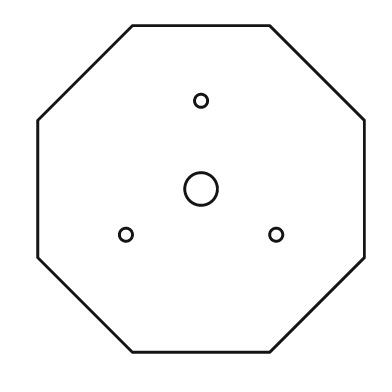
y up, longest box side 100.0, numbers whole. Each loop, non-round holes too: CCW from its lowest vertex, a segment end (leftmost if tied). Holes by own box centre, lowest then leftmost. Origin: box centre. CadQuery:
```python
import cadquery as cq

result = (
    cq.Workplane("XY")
    .moveTo(-21.0, -50.0)
    .lineTo(21.0, -50.0)
    .lineTo(50.0, -21.0)
    .lineTo(50.0, 21.0)
    .lineTo(21.0, 50.0)
    .lineTo(-21.0, 50.0)
    .lineTo(-50.0, 21.0)
    .lineTo(-50.0, -21.0)
    .close()
    .moveTo(-23.0, -14.0)
    .circle(2.0)
    .moveTo(23.0, -14.0)
    .circle(2.0)
    .moveTo(0.0, 0.0)
    .circle(5.0)
    .moveTo(0.0, 27.0)
    .circle(2.0)
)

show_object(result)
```